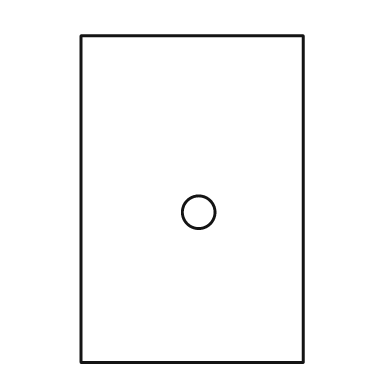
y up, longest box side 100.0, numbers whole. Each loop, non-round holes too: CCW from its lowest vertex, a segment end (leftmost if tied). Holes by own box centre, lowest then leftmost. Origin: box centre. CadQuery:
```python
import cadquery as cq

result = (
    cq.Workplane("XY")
    .moveTo(-34.0, -50.0)
    .lineTo(34.0, -50.0)
    .lineTo(34.0, 50.0)
    .lineTo(-34.0, 50.0)
    .close()
    .moveTo(2.0, -4.0)
    .circle(5.0)
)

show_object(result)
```